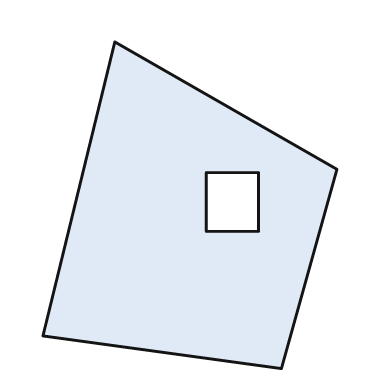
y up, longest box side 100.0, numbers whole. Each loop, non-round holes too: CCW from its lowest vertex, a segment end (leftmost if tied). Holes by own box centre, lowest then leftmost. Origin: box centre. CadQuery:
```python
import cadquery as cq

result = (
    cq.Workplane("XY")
    .moveTo(28.0, -50.0)
    .lineTo(45.0, 11.0)
    .lineTo(-23.0, 50.0)
    .lineTo(-45.0, -40.0)
    .close()
    .moveTo(5.0, -8.0)
    .lineTo(21.0, -8.0)
    .lineTo(21.0, 10.0)
    .lineTo(5.0, 10.0)
    .close()
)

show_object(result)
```